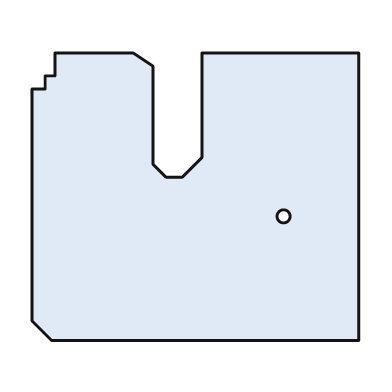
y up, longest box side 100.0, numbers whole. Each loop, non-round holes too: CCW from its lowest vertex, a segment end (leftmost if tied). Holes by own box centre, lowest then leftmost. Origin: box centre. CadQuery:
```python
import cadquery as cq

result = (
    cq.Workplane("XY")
    .moveTo(-44.0, -44.0)
    .lineTo(50.0, -44.0)
    .lineTo(50.0, 44.0)
    .lineTo(2.0, 44.0)
    .lineTo(2.0, 12.0)
    .lineTo(-4.0, 6.0)
    .lineTo(-9.0, 6.0)
    .lineTo(-13.0, 10.0)
    .lineTo(-13.0, 40.0)
    .lineTo(-19.0, 44.0)
    .lineTo(-43.0, 44.0)
    .lineTo(-43.0, 37.0)
    .lineTo(-46.0, 37.0)
    .lineTo(-46.0, 33.0)
    .lineTo(-50.0, 33.0)
    .lineTo(-50.0, -38.0)
    .close()
    .moveTo(27.0, -6.0)
    .circle(2.0)
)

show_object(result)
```